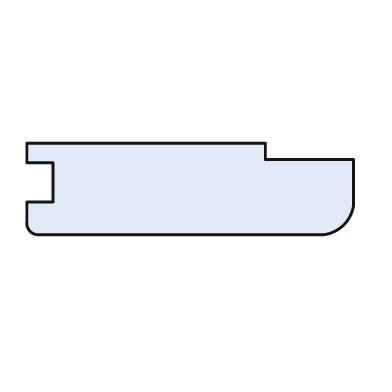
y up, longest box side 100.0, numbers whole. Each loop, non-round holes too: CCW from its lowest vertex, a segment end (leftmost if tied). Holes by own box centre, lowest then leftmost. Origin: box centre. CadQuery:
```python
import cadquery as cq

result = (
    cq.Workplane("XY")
    .moveTo(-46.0, -14.0)
    .lineTo(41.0, -14.0)
    .threePointArc((47.0, -11.0), (50.0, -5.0))
    .lineTo(50.0, 9.0)
    .lineTo(23.0, 9.0)
    .lineTo(23.0, 14.0)
    .lineTo(-50.0, 14.0)
    .lineTo(-50.0, 8.0)
    .lineTo(-42.0, 8.0)
    .lineTo(-42.0, -4.0)
    .lineTo(-50.0, -4.0)
    .lineTo(-50.0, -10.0)
    .threePointArc((-49.0, -13.0), (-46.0, -14.0))
    .close()
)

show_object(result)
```